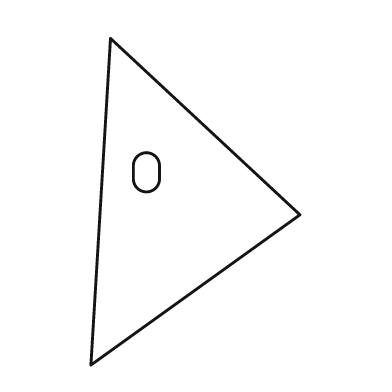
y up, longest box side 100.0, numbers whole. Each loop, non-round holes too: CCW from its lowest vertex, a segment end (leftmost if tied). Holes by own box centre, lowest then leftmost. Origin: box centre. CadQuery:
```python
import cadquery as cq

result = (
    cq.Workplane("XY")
    .moveTo(-32.0, -50.0)
    .lineTo(32.0, -4.0)
    .lineTo(-26.0, 50.0)
    .close()
    .moveTo(-19.0, 7.0)
    .threePointArc((-15.0, 3.0), (-11.0, 7.0))
    .lineTo(-11.0, 11.0)
    .threePointArc((-15.0, 15.0), (-19.0, 11.0))
    .close()
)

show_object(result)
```